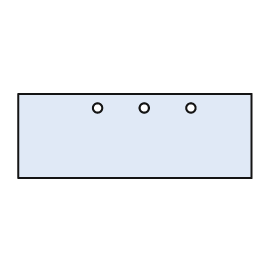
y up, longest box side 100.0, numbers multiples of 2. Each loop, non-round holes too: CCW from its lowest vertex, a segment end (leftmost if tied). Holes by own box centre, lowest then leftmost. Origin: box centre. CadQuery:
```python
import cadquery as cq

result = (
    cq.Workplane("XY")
    .moveTo(-50.0, -18.0)
    .lineTo(50.0, -18.0)
    .lineTo(50.0, 18.0)
    .lineTo(-50.0, 18.0)
    .close()
    .moveTo(-16.0, 12.0)
    .circle(2.0)
    .moveTo(4.0, 12.0)
    .circle(2.0)
    .moveTo(24.0, 12.0)
    .circle(2.0)
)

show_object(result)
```